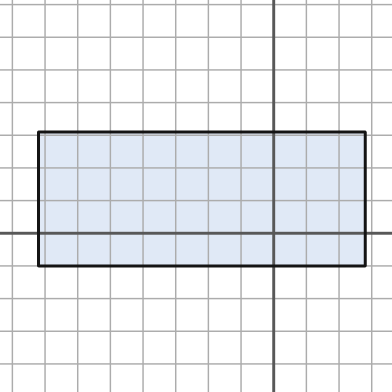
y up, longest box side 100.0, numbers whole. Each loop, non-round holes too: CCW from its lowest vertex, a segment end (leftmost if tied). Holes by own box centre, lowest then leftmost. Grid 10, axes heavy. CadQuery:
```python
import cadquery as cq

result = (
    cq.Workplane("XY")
    .moveTo(-72.0, -10.0)
    .lineTo(28.0, -10.0)
    .lineTo(28.0, 31.0)
    .lineTo(-72.0, 31.0)
    .close()
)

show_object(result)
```